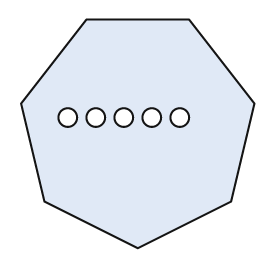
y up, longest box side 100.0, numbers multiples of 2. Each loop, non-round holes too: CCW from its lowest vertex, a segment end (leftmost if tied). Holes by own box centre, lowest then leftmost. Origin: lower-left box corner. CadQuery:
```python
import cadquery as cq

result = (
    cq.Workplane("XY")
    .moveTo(50.0, 0.0)
    .lineTo(90.0, 20.0)
    .lineTo(100.0, 62.0)
    .lineTo(72.0, 98.0)
    .lineTo(28.0, 98.0)
    .lineTo(0.0, 62.0)
    .lineTo(10.0, 20.0)
    .close()
    .moveTo(20.0, 56.0)
    .circle(4.0)
    .moveTo(32.0, 56.0)
    .circle(4.0)
    .moveTo(44.0, 56.0)
    .circle(4.0)
    .moveTo(56.0, 56.0)
    .circle(4.0)
    .moveTo(68.0, 56.0)
    .circle(4.0)
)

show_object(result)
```